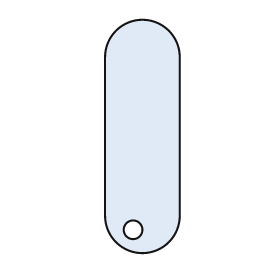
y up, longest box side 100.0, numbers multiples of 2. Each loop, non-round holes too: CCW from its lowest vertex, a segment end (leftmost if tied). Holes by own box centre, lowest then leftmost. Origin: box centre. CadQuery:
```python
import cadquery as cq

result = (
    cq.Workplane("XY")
    .moveTo(-16.0, -34.0)
    .threePointArc((0.0, -50.0), (16.0, -34.0))
    .lineTo(16.0, 34.0)
    .threePointArc((0.0, 50.0), (-16.0, 34.0))
    .close()
    .moveTo(-4.0, -40.0)
    .circle(4.0)
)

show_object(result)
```